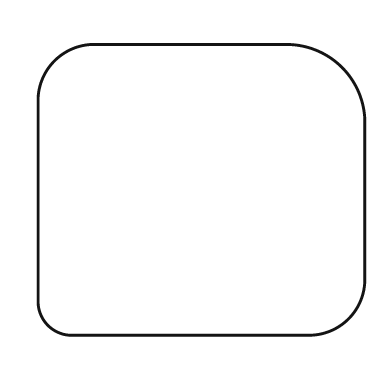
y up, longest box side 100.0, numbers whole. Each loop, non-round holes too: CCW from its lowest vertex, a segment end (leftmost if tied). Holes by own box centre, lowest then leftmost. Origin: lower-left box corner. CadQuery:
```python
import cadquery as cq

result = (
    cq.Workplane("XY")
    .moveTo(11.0, 0.0)
    .lineTo(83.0, 0.0)
    .threePointArc((95.0, 5.0), (100.0, 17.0))
    .lineTo(100.0, 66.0)
    .threePointArc((93.0, 82.0), (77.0, 89.0))
    .lineTo(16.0, 89.0)
    .threePointArc((5.0, 84.0), (0.0, 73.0))
    .lineTo(0.0, 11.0)
    .threePointArc((3.0, 3.0), (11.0, 0.0))
    .close()
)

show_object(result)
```